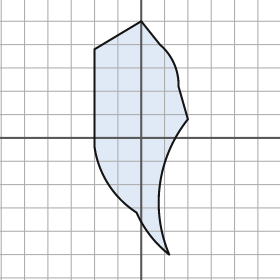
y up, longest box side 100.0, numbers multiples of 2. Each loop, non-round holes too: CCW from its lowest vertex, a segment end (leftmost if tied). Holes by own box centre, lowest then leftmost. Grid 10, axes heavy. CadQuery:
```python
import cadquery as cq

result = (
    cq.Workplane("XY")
    .moveTo(12.0, -50.0)
    .threePointArc((8.0, -20.0), (20.0, 8.0))
    .lineTo(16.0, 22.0)
    .threePointArc((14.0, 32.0), (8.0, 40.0))
    .lineTo(0.0, 50.0)
    .lineTo(-20.0, 38.0)
    .lineTo(-20.0, -4.0)
    .threePointArc((-14.0, -20.0), (-2.0, -32.0))
    .threePointArc((4.0, -42.0), (12.0, -50.0))
    .close()
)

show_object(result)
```